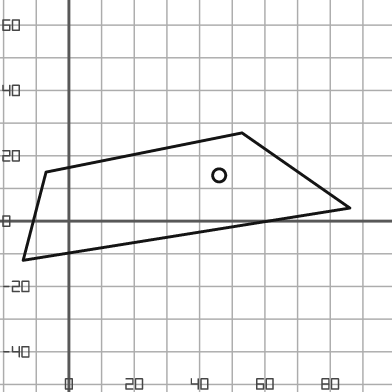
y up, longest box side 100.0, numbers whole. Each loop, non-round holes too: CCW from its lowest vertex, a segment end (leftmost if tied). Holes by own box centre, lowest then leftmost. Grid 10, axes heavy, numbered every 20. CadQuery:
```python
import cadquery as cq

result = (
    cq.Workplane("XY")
    .moveTo(-14.0, -12.0)
    .lineTo(86.0, 4.0)
    .lineTo(53.0, 27.0)
    .lineTo(-7.0, 15.0)
    .close()
    .moveTo(46.0, 14.0)
    .circle(2.0)
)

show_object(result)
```